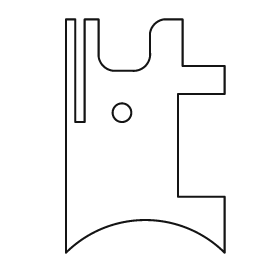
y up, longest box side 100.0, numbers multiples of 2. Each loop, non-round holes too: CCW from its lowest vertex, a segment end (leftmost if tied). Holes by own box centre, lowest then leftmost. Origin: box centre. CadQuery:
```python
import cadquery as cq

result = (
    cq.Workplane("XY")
    .moveTo(-34.0, -50.0)
    .threePointArc((0.0, -36.0), (34.0, -50.0))
    .lineTo(34.0, -26.0)
    .lineTo(14.0, -26.0)
    .lineTo(14.0, 18.0)
    .lineTo(34.0, 18.0)
    .lineTo(34.0, 30.0)
    .lineTo(16.0, 30.0)
    .lineTo(16.0, 50.0)
    .lineTo(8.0, 50.0)
    .threePointArc((4.0, 48.0), (2.0, 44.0))
    .lineTo(2.0, 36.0)
    .threePointArc((0.0, 30.0), (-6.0, 28.0))
    .lineTo(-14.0, 28.0)
    .threePointArc((-18.0, 30.0), (-20.0, 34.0))
    .lineTo(-20.0, 50.0)
    .lineTo(-26.0, 50.0)
    .lineTo(-26.0, 6.0)
    .lineTo(-30.0, 6.0)
    .lineTo(-30.0, 50.0)
    .lineTo(-34.0, 50.0)
    .close()
    .moveTo(-10.0, 10.0)
    .circle(4.0)
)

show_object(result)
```